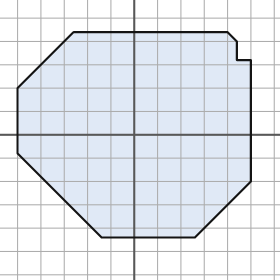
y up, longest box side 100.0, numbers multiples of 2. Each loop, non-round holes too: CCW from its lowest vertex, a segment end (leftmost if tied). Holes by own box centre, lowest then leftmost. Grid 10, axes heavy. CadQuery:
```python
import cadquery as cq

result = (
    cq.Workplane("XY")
    .moveTo(-14.0, -44.0)
    .lineTo(26.0, -44.0)
    .lineTo(50.0, -20.0)
    .lineTo(50.0, 32.0)
    .lineTo(44.0, 32.0)
    .lineTo(44.0, 40.0)
    .lineTo(40.0, 44.0)
    .lineTo(-26.0, 44.0)
    .lineTo(-50.0, 20.0)
    .lineTo(-50.0, -8.0)
    .close()
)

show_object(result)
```